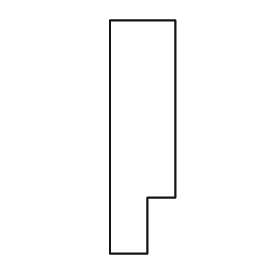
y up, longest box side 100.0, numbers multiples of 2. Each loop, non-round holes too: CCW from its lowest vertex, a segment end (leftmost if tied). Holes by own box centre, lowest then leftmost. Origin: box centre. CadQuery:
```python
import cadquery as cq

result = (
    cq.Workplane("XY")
    .moveTo(-14.0, -50.0)
    .lineTo(2.0, -50.0)
    .lineTo(2.0, -26.0)
    .lineTo(14.0, -26.0)
    .lineTo(14.0, 50.0)
    .lineTo(-14.0, 50.0)
    .close()
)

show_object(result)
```